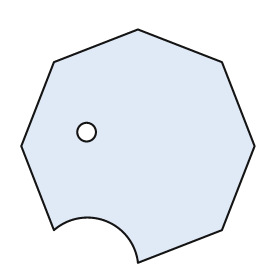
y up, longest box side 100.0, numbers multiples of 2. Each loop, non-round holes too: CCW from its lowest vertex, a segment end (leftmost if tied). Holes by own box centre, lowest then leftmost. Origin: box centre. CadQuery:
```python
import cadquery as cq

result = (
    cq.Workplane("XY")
    .moveTo(0.0, -50.0)
    .lineTo(36.0, -36.0)
    .lineTo(50.0, 0.0)
    .lineTo(36.0, 36.0)
    .lineTo(0.0, 50.0)
    .lineTo(-36.0, 36.0)
    .lineTo(-50.0, 0.0)
    .lineTo(-36.0, -36.0)
    .threePointArc((-14.0, -32.0), (0.0, -50.0))
    .close()
    .moveTo(-22.0, 6.0)
    .circle(4.0)
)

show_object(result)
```